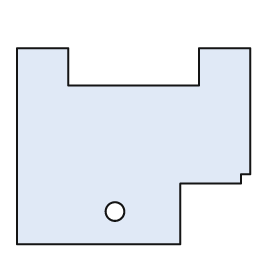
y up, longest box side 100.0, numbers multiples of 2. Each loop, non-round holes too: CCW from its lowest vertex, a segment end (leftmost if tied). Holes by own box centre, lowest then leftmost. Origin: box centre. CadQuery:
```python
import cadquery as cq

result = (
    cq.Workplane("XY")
    .moveTo(-50.0, -42.0)
    .lineTo(20.0, -42.0)
    .lineTo(20.0, -16.0)
    .lineTo(46.0, -16.0)
    .lineTo(46.0, -12.0)
    .lineTo(50.0, -12.0)
    .lineTo(50.0, 42.0)
    .lineTo(28.0, 42.0)
    .lineTo(28.0, 26.0)
    .lineTo(-28.0, 26.0)
    .lineTo(-28.0, 42.0)
    .lineTo(-50.0, 42.0)
    .close()
    .moveTo(-8.0, -28.0)
    .circle(4.0)
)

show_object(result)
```